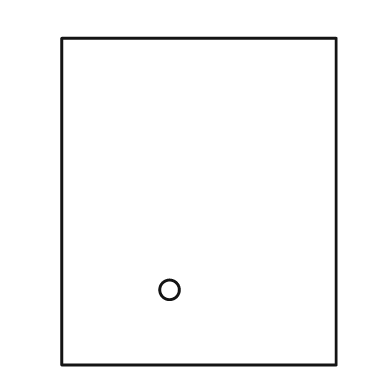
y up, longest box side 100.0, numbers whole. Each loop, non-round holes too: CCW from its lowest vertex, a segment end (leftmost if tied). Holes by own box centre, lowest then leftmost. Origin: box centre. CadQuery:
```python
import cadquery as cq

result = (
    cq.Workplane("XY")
    .moveTo(-42.0, -50.0)
    .lineTo(42.0, -50.0)
    .lineTo(42.0, 50.0)
    .lineTo(-42.0, 50.0)
    .close()
    .moveTo(-9.0, -27.0)
    .circle(3.0)
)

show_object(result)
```